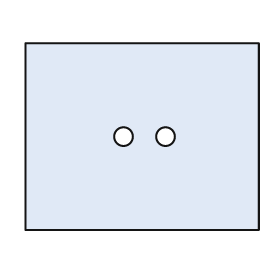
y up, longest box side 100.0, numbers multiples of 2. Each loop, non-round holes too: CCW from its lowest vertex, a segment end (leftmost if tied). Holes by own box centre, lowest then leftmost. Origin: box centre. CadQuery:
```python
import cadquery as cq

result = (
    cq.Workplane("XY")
    .moveTo(-50.0, -40.0)
    .lineTo(50.0, -40.0)
    .lineTo(50.0, 40.0)
    .lineTo(-50.0, 40.0)
    .close()
    .moveTo(-8.0, 0.0)
    .circle(4.0)
    .moveTo(10.0, 0.0)
    .circle(4.0)
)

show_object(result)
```